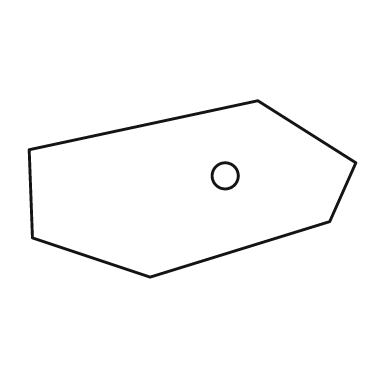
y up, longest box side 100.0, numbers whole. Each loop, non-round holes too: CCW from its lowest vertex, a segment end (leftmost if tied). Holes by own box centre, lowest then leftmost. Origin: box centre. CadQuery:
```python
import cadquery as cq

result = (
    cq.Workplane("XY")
    .moveTo(-13.0, -27.0)
    .lineTo(42.0, -10.0)
    .lineTo(50.0, 8.0)
    .lineTo(20.0, 27.0)
    .lineTo(-50.0, 12.0)
    .lineTo(-49.0, -15.0)
    .close()
    .moveTo(10.0, 4.0)
    .circle(4.0)
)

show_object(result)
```